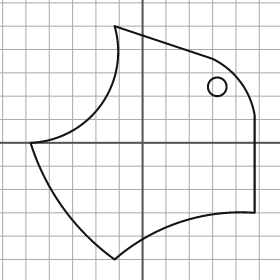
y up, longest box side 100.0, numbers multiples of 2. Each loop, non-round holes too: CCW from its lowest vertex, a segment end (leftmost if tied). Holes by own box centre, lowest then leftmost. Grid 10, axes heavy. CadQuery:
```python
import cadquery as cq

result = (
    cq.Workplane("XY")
    .moveTo(-12.0, -50.0)
    .threePointArc((16.0, -34.0), (48.0, -30.0))
    .lineTo(48.0, 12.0)
    .threePointArc((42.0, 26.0), (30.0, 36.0))
    .lineTo(-12.0, 50.0)
    .threePointArc((-18.0, 16.0), (-48.0, 0.0))
    .threePointArc((-34.0, -28.0), (-12.0, -50.0))
    .close()
    .moveTo(32.0, 24.0)
    .circle(4.0)
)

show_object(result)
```